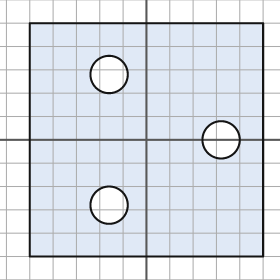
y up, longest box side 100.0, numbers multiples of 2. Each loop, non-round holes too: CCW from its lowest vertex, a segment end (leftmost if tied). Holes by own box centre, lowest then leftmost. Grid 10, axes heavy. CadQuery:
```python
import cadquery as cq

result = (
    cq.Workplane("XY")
    .moveTo(-50.0, -50.0)
    .lineTo(50.0, -50.0)
    .lineTo(50.0, 50.0)
    .lineTo(-50.0, 50.0)
    .close()
    .moveTo(-16.0, -28.0)
    .circle(8.0)
    .moveTo(32.0, 0.0)
    .circle(8.0)
    .moveTo(-16.0, 28.0)
    .circle(8.0)
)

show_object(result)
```